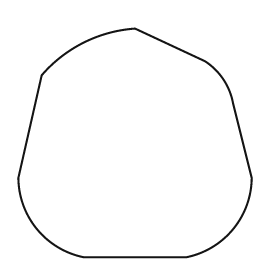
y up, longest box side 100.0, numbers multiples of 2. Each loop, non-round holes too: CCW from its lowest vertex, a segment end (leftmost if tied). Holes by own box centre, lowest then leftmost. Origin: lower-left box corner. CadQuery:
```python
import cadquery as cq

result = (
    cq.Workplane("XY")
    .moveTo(28.0, 0.0)
    .lineTo(72.0, 0.0)
    .threePointArc((92.0, 12.0), (100.0, 34.0))
    .lineTo(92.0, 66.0)
    .threePointArc((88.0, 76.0), (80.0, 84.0))
    .lineTo(50.0, 98.0)
    .threePointArc((28.0, 92.0), (10.0, 78.0))
    .lineTo(0.0, 34.0)
    .threePointArc((8.0, 12.0), (28.0, 0.0))
    .close()
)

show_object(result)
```